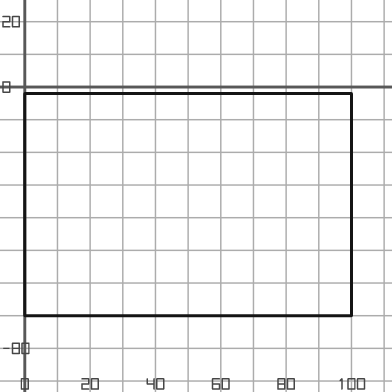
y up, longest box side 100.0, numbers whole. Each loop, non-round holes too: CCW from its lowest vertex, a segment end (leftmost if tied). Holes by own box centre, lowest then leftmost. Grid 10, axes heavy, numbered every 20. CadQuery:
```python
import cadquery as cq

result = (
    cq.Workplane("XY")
    .moveTo(0.0, -70.0)
    .lineTo(100.0, -70.0)
    .lineTo(100.0, -2.0)
    .lineTo(0.0, -2.0)
    .close()
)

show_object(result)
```